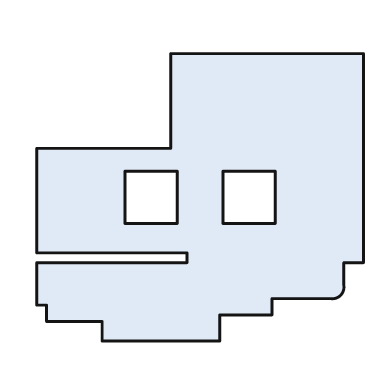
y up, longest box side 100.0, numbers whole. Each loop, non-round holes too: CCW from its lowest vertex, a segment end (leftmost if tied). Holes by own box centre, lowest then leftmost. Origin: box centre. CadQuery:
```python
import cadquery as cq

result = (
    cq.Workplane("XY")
    .moveTo(-30.0, -44.0)
    .lineTo(6.0, -44.0)
    .lineTo(6.0, -36.0)
    .lineTo(22.0, -36.0)
    .lineTo(22.0, -31.0)
    .lineTo(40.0, -31.0)
    .threePointArc((43.0, -30.0), (44.0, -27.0))
    .lineTo(44.0, -20.0)
    .lineTo(50.0, -20.0)
    .lineTo(50.0, 44.0)
    .lineTo(-9.0, 44.0)
    .lineTo(-9.0, 15.0)
    .lineTo(-50.0, 15.0)
    .lineTo(-50.0, -17.0)
    .lineTo(-4.0, -17.0)
    .lineTo(-4.0, -20.0)
    .lineTo(-50.0, -20.0)
    .lineTo(-50.0, -33.0)
    .lineTo(-47.0, -33.0)
    .lineTo(-47.0, -38.0)
    .lineTo(-30.0, -38.0)
    .close()
    .moveTo(-23.0, -8.0)
    .lineTo(-7.0, -8.0)
    .lineTo(-7.0, 8.0)
    .lineTo(-23.0, 8.0)
    .close()
    .moveTo(7.0, -8.0)
    .lineTo(23.0, -8.0)
    .lineTo(23.0, 8.0)
    .lineTo(7.0, 8.0)
    .close()
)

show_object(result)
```